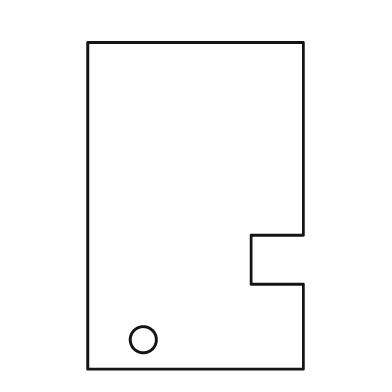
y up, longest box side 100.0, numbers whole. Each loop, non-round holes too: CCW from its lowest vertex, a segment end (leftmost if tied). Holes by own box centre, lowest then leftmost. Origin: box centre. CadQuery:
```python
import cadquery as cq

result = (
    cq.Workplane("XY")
    .moveTo(-33.0, -50.0)
    .lineTo(33.0, -50.0)
    .lineTo(33.0, -24.0)
    .lineTo(17.0, -24.0)
    .lineTo(17.0, -9.0)
    .lineTo(33.0, -9.0)
    .lineTo(33.0, 50.0)
    .lineTo(-33.0, 50.0)
    .close()
    .moveTo(-16.0, -41.0)
    .circle(4.0)
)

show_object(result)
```